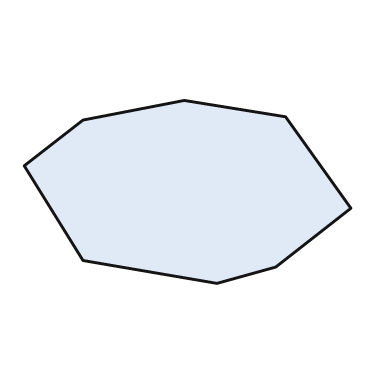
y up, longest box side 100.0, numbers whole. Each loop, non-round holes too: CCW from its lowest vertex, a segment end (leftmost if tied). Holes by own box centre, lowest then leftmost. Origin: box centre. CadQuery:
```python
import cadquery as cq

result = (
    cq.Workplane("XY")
    .moveTo(9.0, -28.0)
    .lineTo(27.0, -23.0)
    .lineTo(50.0, -5.0)
    .lineTo(30.0, 23.0)
    .lineTo(-1.0, 28.0)
    .lineTo(-32.0, 22.0)
    .lineTo(-50.0, 8.0)
    .lineTo(-32.0, -21.0)
    .close()
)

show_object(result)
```